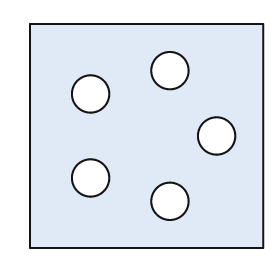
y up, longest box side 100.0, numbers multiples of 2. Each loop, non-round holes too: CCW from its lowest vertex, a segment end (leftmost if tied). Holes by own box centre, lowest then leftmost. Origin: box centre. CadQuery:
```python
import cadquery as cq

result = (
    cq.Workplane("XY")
    .moveTo(-50.0, -48.0)
    .lineTo(50.0, -48.0)
    .lineTo(50.0, 48.0)
    .lineTo(-50.0, 48.0)
    .close()
    .moveTo(10.0, -28.0)
    .circle(8.0)
    .moveTo(-24.0, -18.0)
    .circle(8.0)
    .moveTo(30.0, 0.0)
    .circle(8.0)
    .moveTo(-24.0, 18.0)
    .circle(8.0)
    .moveTo(10.0, 28.0)
    .circle(8.0)
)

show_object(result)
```